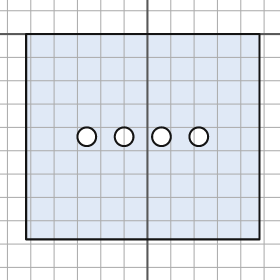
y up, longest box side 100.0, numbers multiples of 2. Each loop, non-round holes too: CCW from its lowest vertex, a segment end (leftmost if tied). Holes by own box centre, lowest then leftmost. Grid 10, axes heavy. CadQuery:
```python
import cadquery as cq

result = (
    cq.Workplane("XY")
    .moveTo(-52.0, -88.0)
    .lineTo(48.0, -88.0)
    .lineTo(48.0, 0.0)
    .lineTo(-52.0, 0.0)
    .close()
    .moveTo(-26.0, -44.0)
    .circle(4.0)
    .moveTo(-10.0, -44.0)
    .circle(4.0)
    .moveTo(6.0, -44.0)
    .circle(4.0)
    .moveTo(22.0, -44.0)
    .circle(4.0)
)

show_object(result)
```